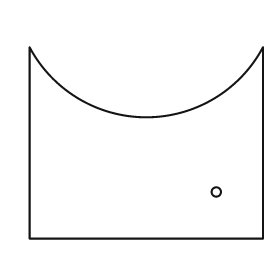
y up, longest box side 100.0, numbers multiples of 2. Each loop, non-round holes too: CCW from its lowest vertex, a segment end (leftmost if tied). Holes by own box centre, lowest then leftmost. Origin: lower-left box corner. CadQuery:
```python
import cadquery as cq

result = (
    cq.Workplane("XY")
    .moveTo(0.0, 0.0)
    .lineTo(100.0, 0.0)
    .lineTo(100.0, 82.0)
    .threePointArc((50.0, 52.0), (0.0, 82.0))
    .close()
    .moveTo(80.0, 20.0)
    .circle(2.0)
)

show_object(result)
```